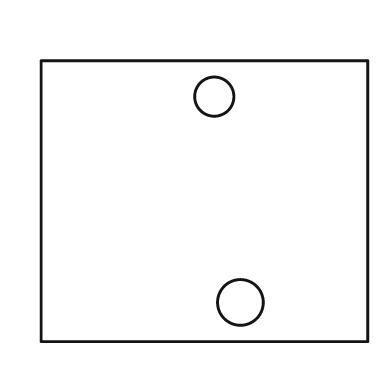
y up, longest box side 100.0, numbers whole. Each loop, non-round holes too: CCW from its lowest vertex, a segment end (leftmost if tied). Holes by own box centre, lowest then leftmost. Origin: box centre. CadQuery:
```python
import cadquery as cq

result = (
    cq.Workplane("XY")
    .moveTo(-50.0, -43.0)
    .lineTo(50.0, -43.0)
    .lineTo(50.0, 43.0)
    .lineTo(-50.0, 43.0)
    .close()
    .moveTo(11.0, -31.0)
    .circle(7.0)
    .moveTo(3.0, 32.0)
    .circle(6.0)
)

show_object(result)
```